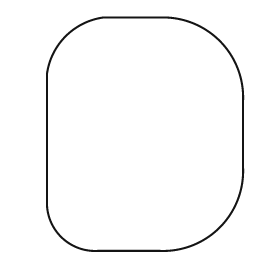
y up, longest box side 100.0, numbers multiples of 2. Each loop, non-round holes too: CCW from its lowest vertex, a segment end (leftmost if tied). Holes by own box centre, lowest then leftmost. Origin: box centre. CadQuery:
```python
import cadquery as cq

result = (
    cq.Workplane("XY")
    .moveTo(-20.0, -50.0)
    .lineTo(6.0, -50.0)
    .threePointArc((32.0, -40.0), (42.0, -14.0))
    .lineTo(42.0, 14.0)
    .threePointArc((32.0, 40.0), (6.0, 50.0))
    .lineTo(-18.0, 50.0)
    .threePointArc((-34.0, 42.0), (-42.0, 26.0))
    .lineTo(-42.0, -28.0)
    .threePointArc((-36.0, -44.0), (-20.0, -50.0))
    .close()
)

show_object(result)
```